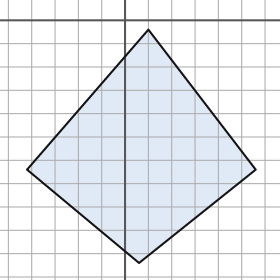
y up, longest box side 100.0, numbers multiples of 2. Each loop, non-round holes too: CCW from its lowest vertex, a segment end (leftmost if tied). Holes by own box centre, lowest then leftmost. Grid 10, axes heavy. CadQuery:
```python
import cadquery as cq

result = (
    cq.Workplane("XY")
    .moveTo(6.0, -104.0)
    .lineTo(56.0, -64.0)
    .lineTo(10.0, -4.0)
    .lineTo(-42.0, -64.0)
    .close()
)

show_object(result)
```